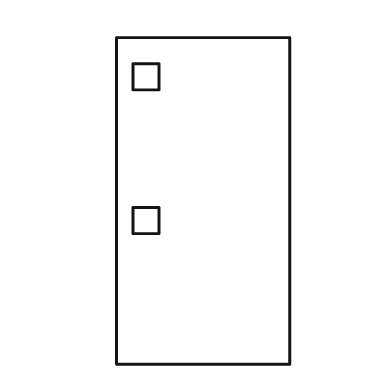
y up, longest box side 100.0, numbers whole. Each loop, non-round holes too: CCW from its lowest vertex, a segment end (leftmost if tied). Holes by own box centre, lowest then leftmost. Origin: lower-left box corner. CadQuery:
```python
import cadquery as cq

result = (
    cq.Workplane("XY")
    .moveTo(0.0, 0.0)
    .lineTo(53.0, 0.0)
    .lineTo(53.0, 100.0)
    .lineTo(0.0, 100.0)
    .close()
    .moveTo(5.0, 40.0)
    .lineTo(13.0, 40.0)
    .lineTo(13.0, 48.0)
    .lineTo(5.0, 48.0)
    .close()
    .moveTo(5.0, 84.0)
    .lineTo(13.0, 84.0)
    .lineTo(13.0, 92.0)
    .lineTo(5.0, 92.0)
    .close()
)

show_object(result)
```